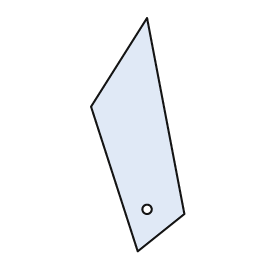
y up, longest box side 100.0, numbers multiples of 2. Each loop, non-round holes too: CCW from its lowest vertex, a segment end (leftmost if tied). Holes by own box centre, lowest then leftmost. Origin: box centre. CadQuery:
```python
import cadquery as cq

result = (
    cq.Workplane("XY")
    .moveTo(0.0, -50.0)
    .lineTo(20.0, -34.0)
    .lineTo(4.0, 50.0)
    .lineTo(-20.0, 12.0)
    .close()
    .moveTo(4.0, -32.0)
    .circle(2.0)
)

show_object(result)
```